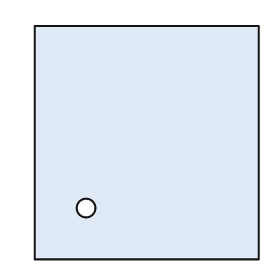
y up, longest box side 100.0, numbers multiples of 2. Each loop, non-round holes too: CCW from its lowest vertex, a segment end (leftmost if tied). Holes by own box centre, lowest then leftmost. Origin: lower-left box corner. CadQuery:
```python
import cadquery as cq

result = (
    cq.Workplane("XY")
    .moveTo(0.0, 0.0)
    .lineTo(96.0, 0.0)
    .lineTo(96.0, 100.0)
    .lineTo(0.0, 100.0)
    .close()
    .moveTo(22.0, 22.0)
    .circle(4.0)
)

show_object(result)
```